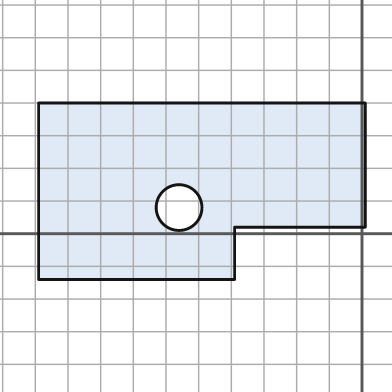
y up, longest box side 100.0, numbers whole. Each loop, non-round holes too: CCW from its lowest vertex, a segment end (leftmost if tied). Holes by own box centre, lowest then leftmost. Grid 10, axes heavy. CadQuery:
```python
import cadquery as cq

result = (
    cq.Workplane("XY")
    .moveTo(-99.0, -14.0)
    .lineTo(-39.0, -14.0)
    .lineTo(-39.0, 2.0)
    .lineTo(1.0, 2.0)
    .lineTo(1.0, 40.0)
    .lineTo(-99.0, 40.0)
    .close()
    .moveTo(-56.0, 8.0)
    .circle(7.0)
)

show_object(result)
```